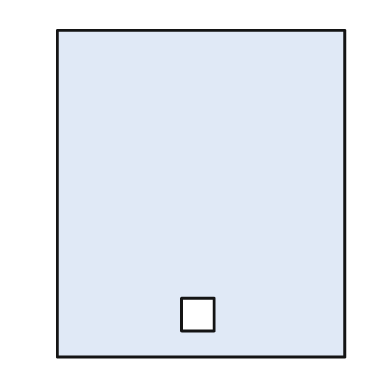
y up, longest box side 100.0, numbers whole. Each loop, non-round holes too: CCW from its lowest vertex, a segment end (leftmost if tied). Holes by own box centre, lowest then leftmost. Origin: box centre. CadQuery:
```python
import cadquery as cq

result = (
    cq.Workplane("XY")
    .moveTo(-44.0, -50.0)
    .lineTo(44.0, -50.0)
    .lineTo(44.0, 50.0)
    .lineTo(-44.0, 50.0)
    .close()
    .moveTo(-6.0, -42.0)
    .lineTo(4.0, -42.0)
    .lineTo(4.0, -32.0)
    .lineTo(-6.0, -32.0)
    .close()
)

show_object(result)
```